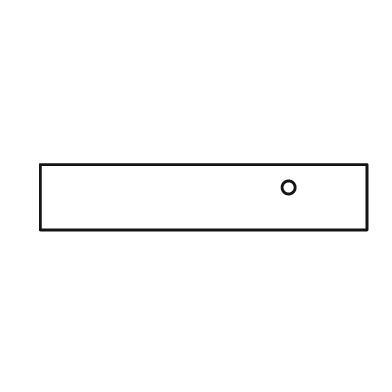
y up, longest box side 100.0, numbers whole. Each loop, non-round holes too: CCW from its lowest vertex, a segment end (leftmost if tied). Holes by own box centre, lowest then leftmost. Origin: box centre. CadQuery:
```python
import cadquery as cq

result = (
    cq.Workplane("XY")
    .moveTo(-50.0, -10.0)
    .lineTo(50.0, -10.0)
    .lineTo(50.0, 10.0)
    .lineTo(-50.0, 10.0)
    .close()
    .moveTo(26.0, 3.0)
    .circle(2.0)
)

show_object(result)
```